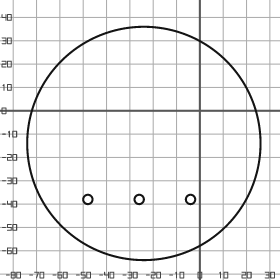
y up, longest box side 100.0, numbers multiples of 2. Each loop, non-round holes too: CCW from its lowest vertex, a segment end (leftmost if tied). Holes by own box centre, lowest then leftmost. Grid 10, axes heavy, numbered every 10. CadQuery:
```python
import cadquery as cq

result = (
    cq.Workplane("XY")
    .moveTo(-24.0, -14.0)
    .circle(50.0)
    .moveTo(-48.0, -38.0)
    .circle(2.0)
    .moveTo(-26.0, -38.0)
    .circle(2.0)
    .moveTo(-4.0, -38.0)
    .circle(2.0)
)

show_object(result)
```